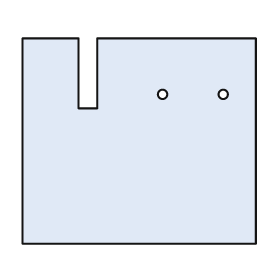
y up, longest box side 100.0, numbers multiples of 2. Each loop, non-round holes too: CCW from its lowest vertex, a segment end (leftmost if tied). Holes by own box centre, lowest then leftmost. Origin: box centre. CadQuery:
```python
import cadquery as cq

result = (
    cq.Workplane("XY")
    .moveTo(-50.0, -44.0)
    .lineTo(50.0, -44.0)
    .lineTo(50.0, 44.0)
    .lineTo(-18.0, 44.0)
    .lineTo(-18.0, 14.0)
    .lineTo(-26.0, 14.0)
    .lineTo(-26.0, 44.0)
    .lineTo(-50.0, 44.0)
    .close()
    .moveTo(10.0, 20.0)
    .circle(2.0)
    .moveTo(36.0, 20.0)
    .circle(2.0)
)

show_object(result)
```